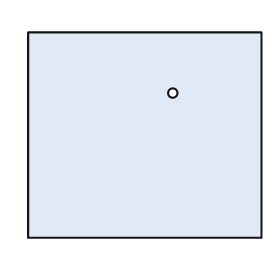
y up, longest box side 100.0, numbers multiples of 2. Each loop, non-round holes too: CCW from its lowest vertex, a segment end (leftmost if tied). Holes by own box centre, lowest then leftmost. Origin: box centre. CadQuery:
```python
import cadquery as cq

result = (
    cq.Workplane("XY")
    .moveTo(-50.0, -44.0)
    .lineTo(50.0, -44.0)
    .lineTo(50.0, 44.0)
    .lineTo(-50.0, 44.0)
    .close()
    .moveTo(12.0, 18.0)
    .circle(2.0)
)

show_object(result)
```